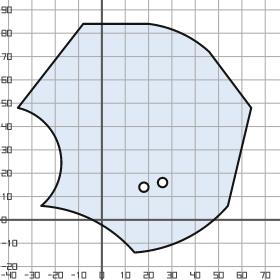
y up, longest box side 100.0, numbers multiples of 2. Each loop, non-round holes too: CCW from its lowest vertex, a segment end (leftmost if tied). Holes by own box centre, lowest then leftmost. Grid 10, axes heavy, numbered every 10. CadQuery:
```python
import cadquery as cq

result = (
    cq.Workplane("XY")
    .moveTo(14.0, -14.0)
    .threePointArc((36.0, -8.0), (54.0, 6.0))
    .lineTo(64.0, 48.0)
    .lineTo(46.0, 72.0)
    .threePointArc((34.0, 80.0), (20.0, 84.0))
    .lineTo(-8.0, 84.0)
    .lineTo(-36.0, 48.0)
    .threePointArc((-18.0, 30.0), (-26.0, 6.0))
    .threePointArc((-4.0, 0.0), (14.0, -14.0))
    .close()
    .moveTo(18.0, 14.0)
    .circle(2.0)
    .moveTo(26.0, 16.0)
    .circle(2.0)
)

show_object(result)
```